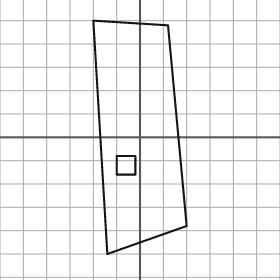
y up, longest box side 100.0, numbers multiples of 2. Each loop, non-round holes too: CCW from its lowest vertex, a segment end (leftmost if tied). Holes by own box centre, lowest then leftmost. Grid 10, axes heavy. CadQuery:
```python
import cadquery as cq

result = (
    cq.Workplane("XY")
    .moveTo(-14.0, -50.0)
    .lineTo(20.0, -38.0)
    .lineTo(12.0, 48.0)
    .lineTo(-20.0, 50.0)
    .close()
    .moveTo(-10.0, -16.0)
    .lineTo(-2.0, -16.0)
    .lineTo(-2.0, -8.0)
    .lineTo(-10.0, -8.0)
    .close()
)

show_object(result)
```